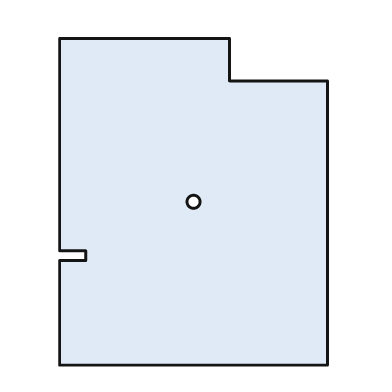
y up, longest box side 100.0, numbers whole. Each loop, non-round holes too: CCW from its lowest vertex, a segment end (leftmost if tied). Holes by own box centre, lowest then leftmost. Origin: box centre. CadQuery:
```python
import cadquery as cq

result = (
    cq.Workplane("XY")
    .moveTo(-41.0, -50.0)
    .lineTo(41.0, -50.0)
    .lineTo(41.0, 37.0)
    .lineTo(11.0, 37.0)
    .lineTo(11.0, 50.0)
    .lineTo(-41.0, 50.0)
    .lineTo(-41.0, -15.0)
    .lineTo(-33.0, -15.0)
    .lineTo(-33.0, -18.0)
    .lineTo(-41.0, -18.0)
    .close()
    .moveTo(0.0, 0.0)
    .circle(2.0)
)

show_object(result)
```